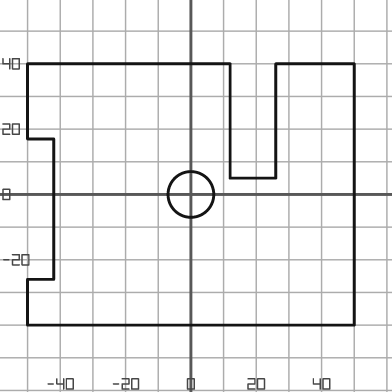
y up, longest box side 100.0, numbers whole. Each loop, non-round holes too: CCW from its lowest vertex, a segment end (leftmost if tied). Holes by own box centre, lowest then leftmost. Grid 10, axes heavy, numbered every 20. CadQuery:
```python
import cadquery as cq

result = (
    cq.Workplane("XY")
    .moveTo(-50.0, -40.0)
    .lineTo(50.0, -40.0)
    .lineTo(50.0, 40.0)
    .lineTo(26.0, 40.0)
    .lineTo(26.0, 5.0)
    .lineTo(12.0, 5.0)
    .lineTo(12.0, 40.0)
    .lineTo(-50.0, 40.0)
    .lineTo(-50.0, 17.0)
    .lineTo(-42.0, 17.0)
    .lineTo(-42.0, -26.0)
    .lineTo(-50.0, -26.0)
    .close()
    .moveTo(0.0, 0.0)
    .circle(7.0)
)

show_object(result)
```